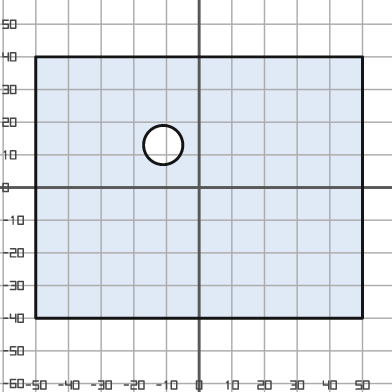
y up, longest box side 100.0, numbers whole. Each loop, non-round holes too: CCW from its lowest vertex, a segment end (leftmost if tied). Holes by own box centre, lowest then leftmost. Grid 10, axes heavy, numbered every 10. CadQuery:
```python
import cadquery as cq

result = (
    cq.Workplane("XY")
    .moveTo(-50.0, -40.0)
    .lineTo(50.0, -40.0)
    .lineTo(50.0, 40.0)
    .lineTo(-50.0, 40.0)
    .close()
    .moveTo(-11.0, 13.0)
    .circle(6.0)
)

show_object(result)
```